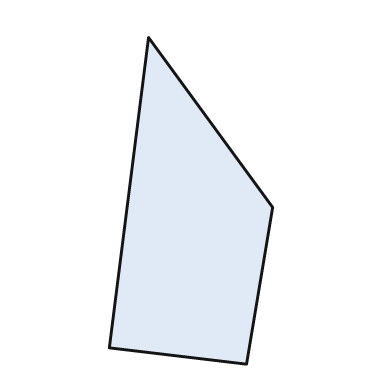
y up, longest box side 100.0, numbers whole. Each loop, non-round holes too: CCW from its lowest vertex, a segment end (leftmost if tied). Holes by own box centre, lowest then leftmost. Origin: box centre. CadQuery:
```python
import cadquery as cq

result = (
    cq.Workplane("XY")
    .moveTo(17.0, -50.0)
    .lineTo(25.0, -2.0)
    .lineTo(-13.0, 50.0)
    .lineTo(-25.0, -45.0)
    .close()
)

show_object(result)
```